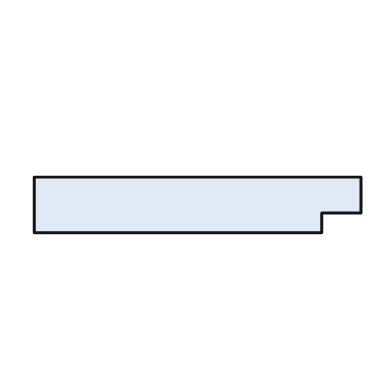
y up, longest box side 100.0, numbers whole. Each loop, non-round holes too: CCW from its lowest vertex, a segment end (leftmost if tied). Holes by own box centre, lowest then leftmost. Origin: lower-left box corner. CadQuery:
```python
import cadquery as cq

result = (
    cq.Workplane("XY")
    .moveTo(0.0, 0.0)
    .lineTo(88.0, 0.0)
    .lineTo(88.0, 6.0)
    .lineTo(100.0, 6.0)
    .lineTo(100.0, 17.0)
    .lineTo(0.0, 17.0)
    .close()
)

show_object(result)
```